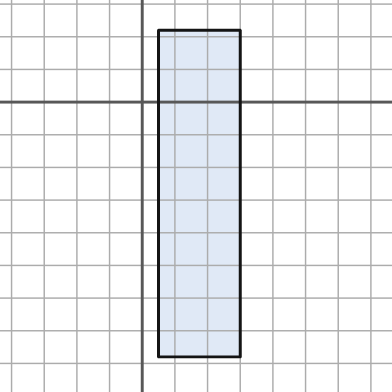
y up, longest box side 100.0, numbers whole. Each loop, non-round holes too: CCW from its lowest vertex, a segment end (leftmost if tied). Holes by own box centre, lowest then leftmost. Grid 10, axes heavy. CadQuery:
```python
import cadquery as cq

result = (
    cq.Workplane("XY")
    .moveTo(5.0, -78.0)
    .lineTo(30.0, -78.0)
    .lineTo(30.0, 22.0)
    .lineTo(5.0, 22.0)
    .close()
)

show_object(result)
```